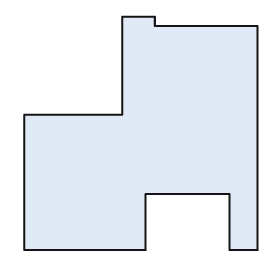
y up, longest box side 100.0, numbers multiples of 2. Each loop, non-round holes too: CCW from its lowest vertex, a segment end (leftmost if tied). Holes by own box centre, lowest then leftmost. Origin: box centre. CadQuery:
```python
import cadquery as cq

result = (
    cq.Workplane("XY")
    .moveTo(-50.0, -50.0)
    .lineTo(2.0, -50.0)
    .lineTo(2.0, -26.0)
    .lineTo(38.0, -26.0)
    .lineTo(38.0, -50.0)
    .lineTo(50.0, -50.0)
    .lineTo(50.0, 46.0)
    .lineTo(6.0, 46.0)
    .lineTo(6.0, 50.0)
    .lineTo(-8.0, 50.0)
    .lineTo(-8.0, 8.0)
    .lineTo(-50.0, 8.0)
    .close()
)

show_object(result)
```